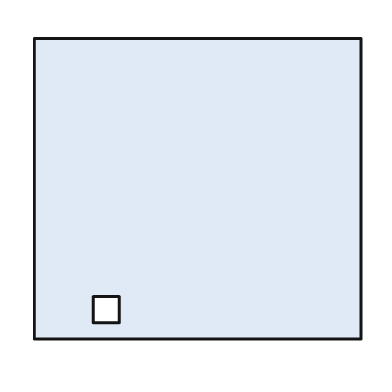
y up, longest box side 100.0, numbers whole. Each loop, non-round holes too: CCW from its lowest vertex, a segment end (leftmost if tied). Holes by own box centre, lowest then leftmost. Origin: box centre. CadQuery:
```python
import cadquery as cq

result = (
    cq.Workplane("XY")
    .moveTo(-50.0, -46.0)
    .lineTo(50.0, -46.0)
    .lineTo(50.0, 46.0)
    .lineTo(-50.0, 46.0)
    .close()
    .moveTo(-32.0, -41.0)
    .lineTo(-24.0, -41.0)
    .lineTo(-24.0, -33.0)
    .lineTo(-32.0, -33.0)
    .close()
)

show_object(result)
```